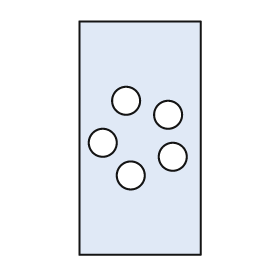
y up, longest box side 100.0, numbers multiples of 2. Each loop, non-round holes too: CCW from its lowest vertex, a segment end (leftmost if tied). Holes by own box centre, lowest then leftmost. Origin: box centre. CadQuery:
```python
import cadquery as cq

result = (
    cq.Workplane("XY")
    .moveTo(-26.0, -50.0)
    .lineTo(26.0, -50.0)
    .lineTo(26.0, 50.0)
    .lineTo(-26.0, 50.0)
    .close()
    .moveTo(-4.0, -16.0)
    .circle(6.0)
    .moveTo(14.0, -8.0)
    .circle(6.0)
    .moveTo(-16.0, -2.0)
    .circle(6.0)
    .moveTo(12.0, 10.0)
    .circle(6.0)
    .moveTo(-6.0, 16.0)
    .circle(6.0)
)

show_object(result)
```